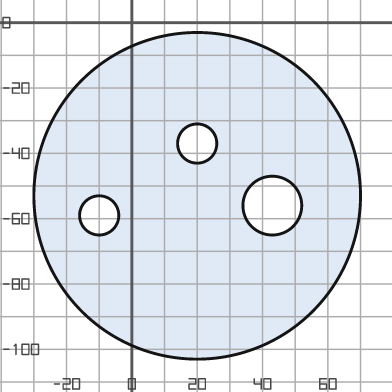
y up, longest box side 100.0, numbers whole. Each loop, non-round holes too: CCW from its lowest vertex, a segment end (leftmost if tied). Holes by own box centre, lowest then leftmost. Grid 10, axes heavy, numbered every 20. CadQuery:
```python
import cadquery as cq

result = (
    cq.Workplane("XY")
    .moveTo(20.0, -53.0)
    .circle(50.0)
    .moveTo(-10.0, -59.0)
    .circle(6.0)
    .moveTo(43.0, -56.0)
    .circle(9.0)
    .moveTo(20.0, -37.0)
    .circle(6.0)
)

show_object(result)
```